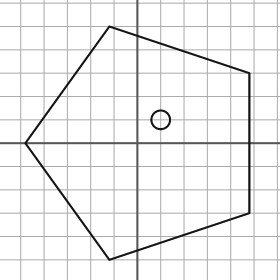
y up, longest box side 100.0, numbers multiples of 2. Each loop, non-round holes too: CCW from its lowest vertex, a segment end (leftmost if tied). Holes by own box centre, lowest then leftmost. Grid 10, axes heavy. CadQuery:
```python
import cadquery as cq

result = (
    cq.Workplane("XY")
    .moveTo(-12.0, -50.0)
    .lineTo(48.0, -30.0)
    .lineTo(48.0, 30.0)
    .lineTo(-12.0, 50.0)
    .lineTo(-48.0, 0.0)
    .close()
    .moveTo(10.0, 10.0)
    .circle(4.0)
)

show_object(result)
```